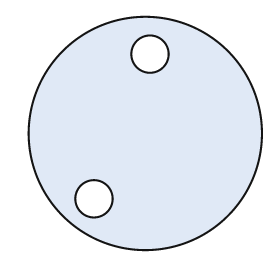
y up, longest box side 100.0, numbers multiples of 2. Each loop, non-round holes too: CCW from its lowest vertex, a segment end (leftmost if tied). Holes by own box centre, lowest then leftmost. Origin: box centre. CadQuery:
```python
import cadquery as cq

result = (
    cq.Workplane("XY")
    .moveTo(0.0, 0.0)
    .circle(50.0)
    .moveTo(-22.0, -28.0)
    .circle(8.0)
    .moveTo(2.0, 34.0)
    .circle(8.0)
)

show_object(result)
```